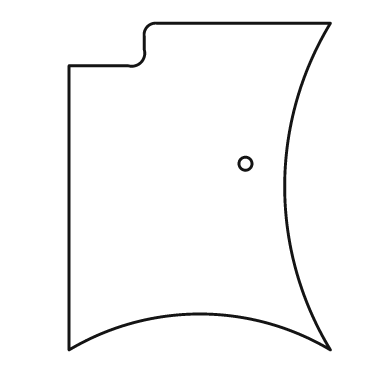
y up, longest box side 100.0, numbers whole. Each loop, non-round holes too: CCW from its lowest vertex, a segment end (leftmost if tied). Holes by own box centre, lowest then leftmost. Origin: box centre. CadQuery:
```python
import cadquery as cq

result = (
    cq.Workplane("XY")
    .moveTo(-40.0, -50.0)
    .threePointArc((0.0, -39.0), (40.0, -50.0))
    .threePointArc((26.0, 0.0), (40.0, 50.0))
    .lineTo(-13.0, 50.0)
    .threePointArc((-16.0, 49.0), (-17.0, 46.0))
    .lineTo(-17.0, 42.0)
    .threePointArc((-18.0, 38.0), (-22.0, 37.0))
    .lineTo(-40.0, 37.0)
    .close()
    .moveTo(14.0, 7.0)
    .circle(2.0)
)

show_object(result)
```